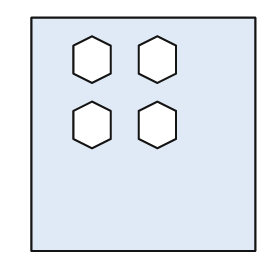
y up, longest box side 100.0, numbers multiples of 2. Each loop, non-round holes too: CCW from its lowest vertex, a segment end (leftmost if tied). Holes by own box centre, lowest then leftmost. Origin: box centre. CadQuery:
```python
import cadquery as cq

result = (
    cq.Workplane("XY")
    .moveTo(-48.0, -50.0)
    .lineTo(48.0, -50.0)
    .lineTo(48.0, 50.0)
    .lineTo(-48.0, 50.0)
    .close()
    .moveTo(-22.0, -6.0)
    .lineTo(-14.0, -2.0)
    .lineTo(-14.0, 10.0)
    .lineTo(-22.0, 14.0)
    .lineTo(-30.0, 10.0)
    .lineTo(-30.0, -2.0)
    .close()
    .moveTo(6.0, -6.0)
    .lineTo(14.0, -2.0)
    .lineTo(14.0, 10.0)
    .lineTo(6.0, 14.0)
    .lineTo(-2.0, 10.0)
    .lineTo(-2.0, -2.0)
    .close()
    .moveTo(-22.0, 22.0)
    .lineTo(-14.0, 26.0)
    .lineTo(-14.0, 38.0)
    .lineTo(-22.0, 42.0)
    .lineTo(-30.0, 38.0)
    .lineTo(-30.0, 26.0)
    .close()
    .moveTo(6.0, 22.0)
    .lineTo(14.0, 26.0)
    .lineTo(14.0, 38.0)
    .lineTo(6.0, 42.0)
    .lineTo(-2.0, 38.0)
    .lineTo(-2.0, 26.0)
    .close()
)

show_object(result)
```